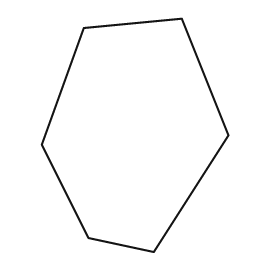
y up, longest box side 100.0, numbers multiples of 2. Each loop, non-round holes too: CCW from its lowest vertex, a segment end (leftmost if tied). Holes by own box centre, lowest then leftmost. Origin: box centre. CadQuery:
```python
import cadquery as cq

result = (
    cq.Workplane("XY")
    .moveTo(8.0, -50.0)
    .lineTo(40.0, 0.0)
    .lineTo(20.0, 50.0)
    .lineTo(-22.0, 46.0)
    .lineTo(-40.0, -4.0)
    .lineTo(-20.0, -44.0)
    .close()
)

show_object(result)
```